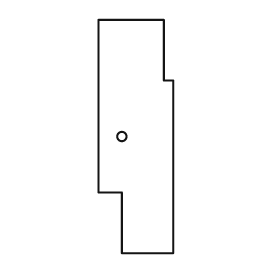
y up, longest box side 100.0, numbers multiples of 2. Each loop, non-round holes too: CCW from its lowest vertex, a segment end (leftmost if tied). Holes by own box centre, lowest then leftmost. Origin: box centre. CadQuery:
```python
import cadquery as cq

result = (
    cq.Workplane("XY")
    .moveTo(-6.0, -50.0)
    .lineTo(16.0, -50.0)
    .lineTo(16.0, 24.0)
    .lineTo(12.0, 24.0)
    .lineTo(12.0, 50.0)
    .lineTo(-16.0, 50.0)
    .lineTo(-16.0, -24.0)
    .lineTo(-6.0, -24.0)
    .close()
    .moveTo(-6.0, 0.0)
    .circle(2.0)
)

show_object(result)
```